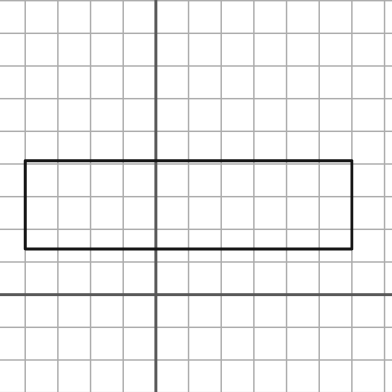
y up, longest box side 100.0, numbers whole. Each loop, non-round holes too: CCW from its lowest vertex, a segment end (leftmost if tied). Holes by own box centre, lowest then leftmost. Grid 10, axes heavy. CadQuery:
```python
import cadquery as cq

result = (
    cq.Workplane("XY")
    .moveTo(-40.0, 14.0)
    .lineTo(60.0, 14.0)
    .lineTo(60.0, 41.0)
    .lineTo(-40.0, 41.0)
    .close()
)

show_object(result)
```